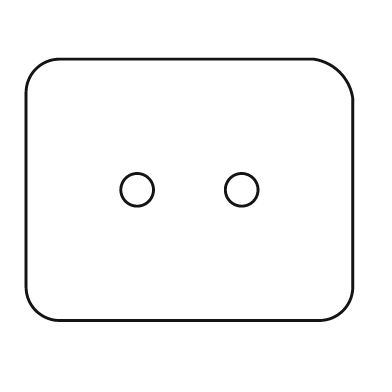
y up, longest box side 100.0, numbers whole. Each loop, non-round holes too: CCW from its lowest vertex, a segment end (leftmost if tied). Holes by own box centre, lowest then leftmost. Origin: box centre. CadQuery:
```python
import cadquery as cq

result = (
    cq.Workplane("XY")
    .moveTo(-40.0, -40.0)
    .lineTo(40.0, -40.0)
    .threePointArc((47.0, -37.0), (50.0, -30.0))
    .lineTo(50.0, 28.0)
    .threePointArc((46.0, 36.0), (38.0, 40.0))
    .lineTo(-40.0, 40.0)
    .threePointArc((-47.0, 37.0), (-50.0, 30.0))
    .lineTo(-50.0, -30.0)
    .threePointArc((-47.0, -37.0), (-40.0, -40.0))
    .close()
    .moveTo(-16.0, 0.0)
    .circle(5.0)
    .moveTo(16.0, 0.0)
    .circle(5.0)
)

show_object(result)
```